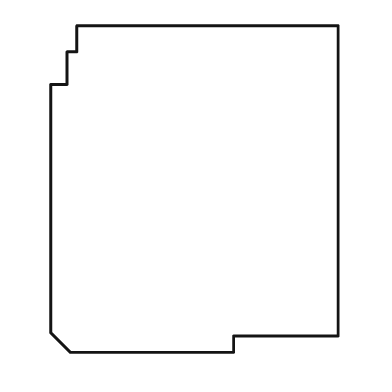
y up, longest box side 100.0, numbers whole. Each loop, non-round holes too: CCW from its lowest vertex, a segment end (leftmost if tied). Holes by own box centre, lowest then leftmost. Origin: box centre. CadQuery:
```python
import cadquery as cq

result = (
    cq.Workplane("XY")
    .moveTo(-38.0, -50.0)
    .lineTo(12.0, -50.0)
    .lineTo(12.0, -45.0)
    .lineTo(44.0, -45.0)
    .lineTo(44.0, 50.0)
    .lineTo(-36.0, 50.0)
    .lineTo(-36.0, 42.0)
    .lineTo(-39.0, 42.0)
    .lineTo(-39.0, 32.0)
    .lineTo(-44.0, 32.0)
    .lineTo(-44.0, -44.0)
    .close()
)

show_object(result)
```